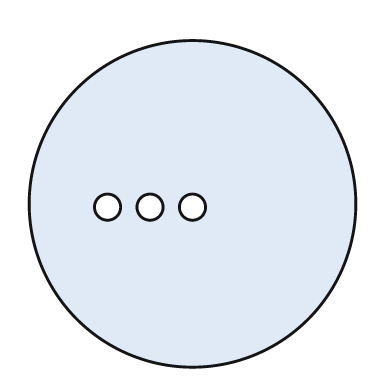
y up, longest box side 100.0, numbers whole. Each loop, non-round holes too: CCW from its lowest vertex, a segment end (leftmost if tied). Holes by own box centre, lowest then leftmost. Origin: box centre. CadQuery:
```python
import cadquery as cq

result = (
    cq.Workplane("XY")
    .moveTo(0.0, 0.0)
    .circle(50.0)
    .moveTo(-26.0, -1.0)
    .circle(4.0)
    .moveTo(-13.0, -1.0)
    .circle(4.0)
    .moveTo(0.0, -1.0)
    .circle(4.0)
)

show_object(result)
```